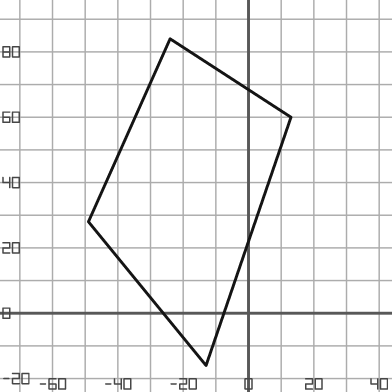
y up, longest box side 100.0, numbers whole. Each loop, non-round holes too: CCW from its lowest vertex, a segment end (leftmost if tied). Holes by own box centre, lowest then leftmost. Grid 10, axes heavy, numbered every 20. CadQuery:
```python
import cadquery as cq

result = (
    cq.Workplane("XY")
    .moveTo(-13.0, -16.0)
    .lineTo(13.0, 60.0)
    .lineTo(-24.0, 84.0)
    .lineTo(-49.0, 28.0)
    .close()
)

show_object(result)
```